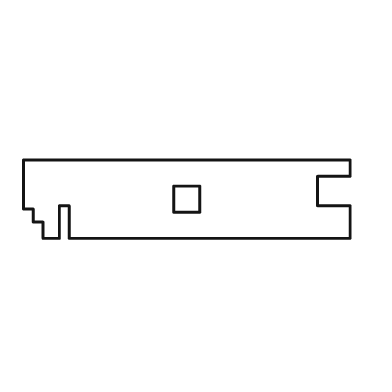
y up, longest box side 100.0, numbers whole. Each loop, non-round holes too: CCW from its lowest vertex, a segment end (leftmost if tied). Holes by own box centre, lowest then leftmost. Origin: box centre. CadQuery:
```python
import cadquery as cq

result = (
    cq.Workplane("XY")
    .moveTo(-44.0, -12.0)
    .lineTo(-39.0, -12.0)
    .lineTo(-39.0, -2.0)
    .lineTo(-36.0, -2.0)
    .lineTo(-36.0, -12.0)
    .lineTo(50.0, -12.0)
    .lineTo(50.0, -2.0)
    .lineTo(40.0, -2.0)
    .lineTo(40.0, 7.0)
    .lineTo(50.0, 7.0)
    .lineTo(50.0, 12.0)
    .lineTo(-50.0, 12.0)
    .lineTo(-50.0, -3.0)
    .lineTo(-47.0, -3.0)
    .lineTo(-47.0, -7.0)
    .lineTo(-44.0, -7.0)
    .close()
    .moveTo(-4.0, -4.0)
    .lineTo(4.0, -4.0)
    .lineTo(4.0, 4.0)
    .lineTo(-4.0, 4.0)
    .close()
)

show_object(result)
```